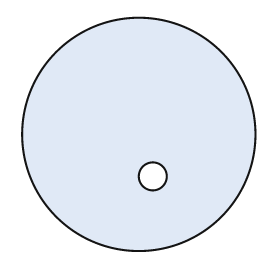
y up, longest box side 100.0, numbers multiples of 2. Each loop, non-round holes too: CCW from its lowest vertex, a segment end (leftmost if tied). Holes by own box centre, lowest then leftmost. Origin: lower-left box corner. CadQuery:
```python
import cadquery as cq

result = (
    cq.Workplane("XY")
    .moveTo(50.0, 50.0)
    .circle(50.0)
    .moveTo(56.0, 32.0)
    .circle(6.0)
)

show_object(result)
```